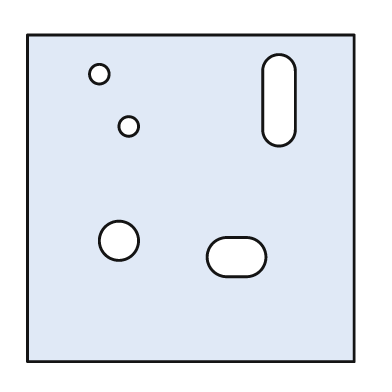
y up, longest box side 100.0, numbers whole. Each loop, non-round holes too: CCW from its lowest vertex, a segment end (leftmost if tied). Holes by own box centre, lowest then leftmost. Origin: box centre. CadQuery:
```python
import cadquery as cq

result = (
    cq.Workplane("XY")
    .moveTo(-50.0, -50.0)
    .lineTo(50.0, -50.0)
    .lineTo(50.0, 50.0)
    .lineTo(-50.0, 50.0)
    .close()
    .moveTo(11.0, -24.0)
    .lineTo(17.0, -24.0)
    .threePointArc((23.0, -18.0), (17.0, -12.0))
    .lineTo(11.0, -12.0)
    .threePointArc((5.0, -18.0), (11.0, -24.0))
    .close()
    .moveTo(-22.0, -13.0)
    .circle(6.0)
    .moveTo(-19.0, 22.0)
    .circle(3.0)
    .moveTo(22.0, 21.0)
    .threePointArc((27.0, 16.0), (32.0, 21.0))
    .lineTo(32.0, 39.0)
    .threePointArc((27.0, 44.0), (22.0, 39.0))
    .close()
    .moveTo(-28.0, 38.0)
    .circle(3.0)
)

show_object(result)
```